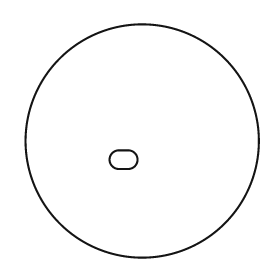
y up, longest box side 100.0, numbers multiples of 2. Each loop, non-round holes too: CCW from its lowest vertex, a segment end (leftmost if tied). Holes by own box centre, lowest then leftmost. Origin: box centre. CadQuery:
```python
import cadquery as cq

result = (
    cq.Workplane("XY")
    .moveTo(0.0, 0.0)
    .circle(50.0)
    .moveTo(-10.0, -12.0)
    .lineTo(-6.0, -12.0)
    .threePointArc((-2.0, -8.0), (-6.0, -4.0))
    .lineTo(-10.0, -4.0)
    .threePointArc((-14.0, -8.0), (-10.0, -12.0))
    .close()
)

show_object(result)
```